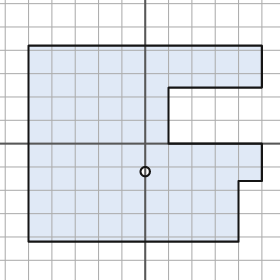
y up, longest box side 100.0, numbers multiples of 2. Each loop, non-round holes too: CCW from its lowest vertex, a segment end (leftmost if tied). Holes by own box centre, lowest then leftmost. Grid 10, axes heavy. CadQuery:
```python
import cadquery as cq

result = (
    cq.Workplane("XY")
    .moveTo(-50.0, -42.0)
    .lineTo(40.0, -42.0)
    .lineTo(40.0, -16.0)
    .lineTo(50.0, -16.0)
    .lineTo(50.0, 0.0)
    .lineTo(10.0, 0.0)
    .lineTo(10.0, 24.0)
    .lineTo(50.0, 24.0)
    .lineTo(50.0, 42.0)
    .lineTo(-50.0, 42.0)
    .close()
    .moveTo(0.0, -12.0)
    .circle(2.0)
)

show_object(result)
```